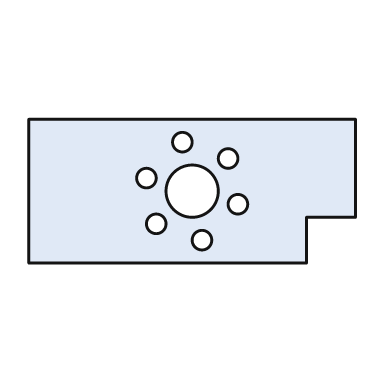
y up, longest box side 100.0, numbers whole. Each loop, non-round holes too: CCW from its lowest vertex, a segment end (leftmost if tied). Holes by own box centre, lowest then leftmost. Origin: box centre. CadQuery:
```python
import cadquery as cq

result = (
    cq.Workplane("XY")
    .moveTo(-50.0, -22.0)
    .lineTo(35.0, -22.0)
    .lineTo(35.0, -8.0)
    .lineTo(50.0, -8.0)
    .lineTo(50.0, 22.0)
    .lineTo(-50.0, 22.0)
    .close()
    .moveTo(3.0, -15.0)
    .circle(3.0)
    .moveTo(-11.0, -10.0)
    .circle(3.0)
    .moveTo(14.0, -4.0)
    .circle(3.0)
    .moveTo(0.0, 0.0)
    .circle(8.0)
    .moveTo(-14.0, 4.0)
    .circle(3.0)
    .moveTo(11.0, 10.0)
    .circle(3.0)
    .moveTo(-3.0, 15.0)
    .circle(3.0)
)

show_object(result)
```